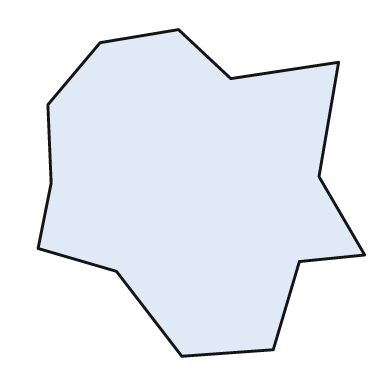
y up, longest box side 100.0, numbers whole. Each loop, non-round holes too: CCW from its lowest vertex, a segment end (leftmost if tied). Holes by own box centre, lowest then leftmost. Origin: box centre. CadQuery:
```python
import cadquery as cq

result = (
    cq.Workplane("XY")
    .moveTo(-6.0, -50.0)
    .lineTo(22.0, -48.0)
    .lineTo(30.0, -21.0)
    .lineTo(50.0, -19.0)
    .lineTo(36.0, 5.0)
    .lineTo(42.0, 40.0)
    .lineTo(9.0, 35.0)
    .lineTo(-7.0, 50.0)
    .lineTo(-31.0, 46.0)
    .lineTo(-47.0, 27.0)
    .lineTo(-46.0, 3.0)
    .lineTo(-50.0, -17.0)
    .lineTo(-26.0, -24.0)
    .close()
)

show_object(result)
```